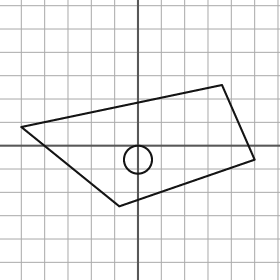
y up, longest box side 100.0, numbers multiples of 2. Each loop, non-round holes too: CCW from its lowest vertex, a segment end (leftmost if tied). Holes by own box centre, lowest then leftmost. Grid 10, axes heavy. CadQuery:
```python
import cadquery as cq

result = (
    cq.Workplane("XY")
    .moveTo(-8.0, -26.0)
    .lineTo(50.0, -6.0)
    .lineTo(36.0, 26.0)
    .lineTo(-50.0, 8.0)
    .close()
    .moveTo(0.0, -6.0)
    .circle(6.0)
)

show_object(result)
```